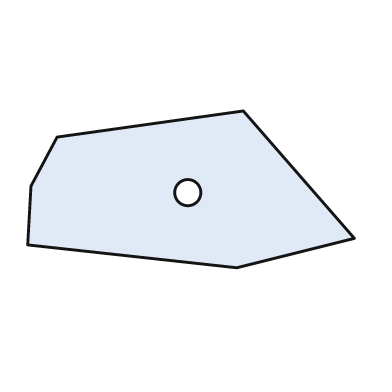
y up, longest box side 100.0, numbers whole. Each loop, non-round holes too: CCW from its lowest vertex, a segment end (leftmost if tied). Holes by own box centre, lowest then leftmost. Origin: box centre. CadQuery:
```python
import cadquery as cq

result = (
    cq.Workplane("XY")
    .moveTo(14.0, -24.0)
    .lineTo(50.0, -15.0)
    .lineTo(16.0, 24.0)
    .lineTo(-41.0, 16.0)
    .lineTo(-49.0, 1.0)
    .lineTo(-50.0, -17.0)
    .close()
    .moveTo(-1.0, -1.0)
    .circle(4.0)
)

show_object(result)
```